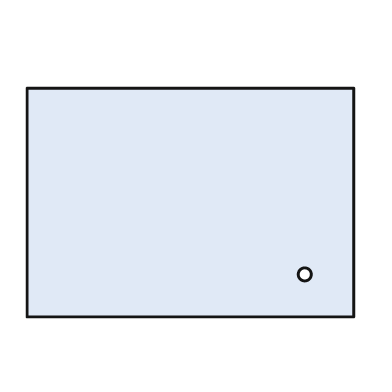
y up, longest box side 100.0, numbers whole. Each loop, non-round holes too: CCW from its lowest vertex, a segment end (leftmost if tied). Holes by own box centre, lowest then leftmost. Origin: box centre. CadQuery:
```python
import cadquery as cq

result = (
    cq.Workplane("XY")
    .moveTo(-50.0, -35.0)
    .lineTo(50.0, -35.0)
    .lineTo(50.0, 35.0)
    .lineTo(-50.0, 35.0)
    .close()
    .moveTo(35.0, -22.0)
    .circle(2.0)
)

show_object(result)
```